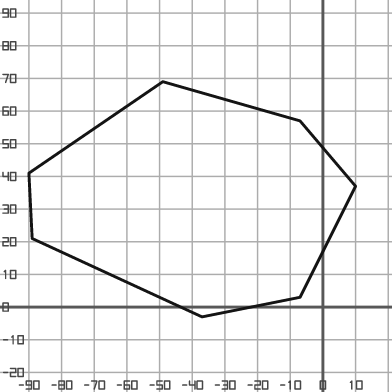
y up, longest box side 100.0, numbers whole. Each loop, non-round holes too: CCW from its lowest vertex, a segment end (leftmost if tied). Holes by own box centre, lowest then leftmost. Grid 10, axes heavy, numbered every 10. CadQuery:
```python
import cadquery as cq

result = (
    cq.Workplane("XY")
    .moveTo(-37.0, -3.0)
    .lineTo(-7.0, 3.0)
    .lineTo(10.0, 37.0)
    .lineTo(-7.0, 57.0)
    .lineTo(-49.0, 69.0)
    .lineTo(-90.0, 41.0)
    .lineTo(-89.0, 21.0)
    .close()
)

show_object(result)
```